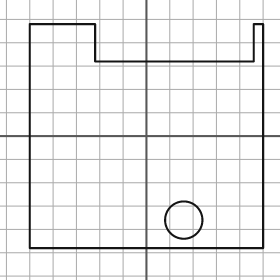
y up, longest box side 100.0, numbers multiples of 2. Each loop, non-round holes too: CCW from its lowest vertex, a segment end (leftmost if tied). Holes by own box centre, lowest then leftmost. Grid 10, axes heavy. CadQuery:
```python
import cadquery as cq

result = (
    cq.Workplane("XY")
    .moveTo(-50.0, -48.0)
    .lineTo(50.0, -48.0)
    .lineTo(50.0, 48.0)
    .lineTo(46.0, 48.0)
    .lineTo(46.0, 32.0)
    .lineTo(-22.0, 32.0)
    .lineTo(-22.0, 48.0)
    .lineTo(-50.0, 48.0)
    .close()
    .moveTo(16.0, -36.0)
    .circle(8.0)
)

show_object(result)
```